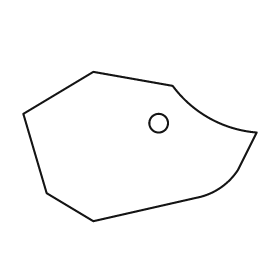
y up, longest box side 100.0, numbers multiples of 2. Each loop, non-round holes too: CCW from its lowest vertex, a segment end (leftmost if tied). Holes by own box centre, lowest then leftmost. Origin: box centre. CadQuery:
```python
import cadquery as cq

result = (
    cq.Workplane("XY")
    .moveTo(-20.0, -32.0)
    .lineTo(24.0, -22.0)
    .threePointArc((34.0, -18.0), (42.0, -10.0))
    .lineTo(50.0, 6.0)
    .threePointArc((30.0, 12.0), (14.0, 26.0))
    .lineTo(-20.0, 32.0)
    .lineTo(-50.0, 14.0)
    .lineTo(-40.0, -20.0)
    .close()
    .moveTo(8.0, 10.0)
    .circle(4.0)
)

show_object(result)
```